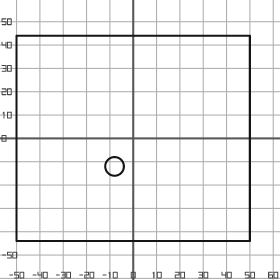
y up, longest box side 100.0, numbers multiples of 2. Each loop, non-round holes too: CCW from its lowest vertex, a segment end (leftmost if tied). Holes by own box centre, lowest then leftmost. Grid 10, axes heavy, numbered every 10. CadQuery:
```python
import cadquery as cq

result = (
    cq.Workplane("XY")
    .moveTo(-50.0, -44.0)
    .lineTo(50.0, -44.0)
    .lineTo(50.0, 44.0)
    .lineTo(-50.0, 44.0)
    .close()
    .moveTo(-8.0, -12.0)
    .circle(4.0)
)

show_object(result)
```